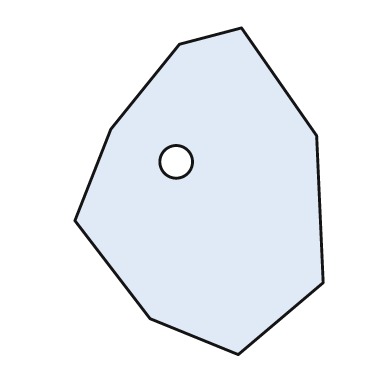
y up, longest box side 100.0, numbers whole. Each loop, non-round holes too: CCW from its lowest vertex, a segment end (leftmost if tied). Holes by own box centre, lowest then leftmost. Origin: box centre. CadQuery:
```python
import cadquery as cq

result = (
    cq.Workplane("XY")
    .moveTo(12.0, -50.0)
    .lineTo(38.0, -28.0)
    .lineTo(36.0, 17.0)
    .lineTo(13.0, 50.0)
    .lineTo(-6.0, 45.0)
    .lineTo(-27.0, 19.0)
    .lineTo(-38.0, -9.0)
    .lineTo(-15.0, -39.0)
    .close()
    .moveTo(-7.0, 9.0)
    .circle(5.0)
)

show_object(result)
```